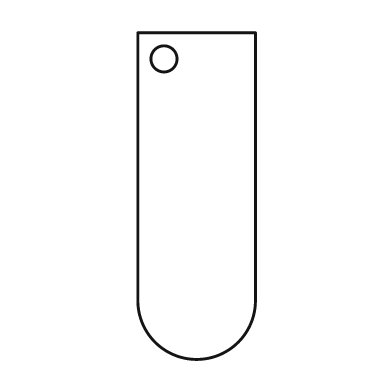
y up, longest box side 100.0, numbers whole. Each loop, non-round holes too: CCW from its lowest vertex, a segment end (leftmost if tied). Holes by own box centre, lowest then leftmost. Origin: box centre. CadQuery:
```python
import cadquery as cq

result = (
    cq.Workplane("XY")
    .moveTo(-18.0, -32.0)
    .threePointArc((0.0, -50.0), (18.0, -32.0))
    .lineTo(18.0, 50.0)
    .lineTo(-18.0, 50.0)
    .close()
    .moveTo(-10.0, 42.0)
    .circle(4.0)
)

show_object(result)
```